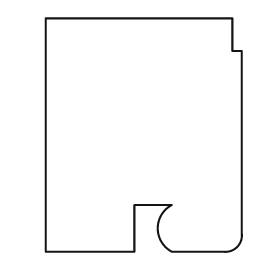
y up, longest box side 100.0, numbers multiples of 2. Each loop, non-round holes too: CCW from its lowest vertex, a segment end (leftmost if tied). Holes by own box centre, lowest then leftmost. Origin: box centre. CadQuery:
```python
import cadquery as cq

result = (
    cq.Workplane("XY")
    .moveTo(-42.0, -50.0)
    .lineTo(-4.0, -50.0)
    .lineTo(-4.0, -30.0)
    .lineTo(12.0, -30.0)
    .threePointArc((6.0, -40.0), (12.0, -50.0))
    .lineTo(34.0, -50.0)
    .threePointArc((40.0, -48.0), (42.0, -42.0))
    .lineTo(42.0, 36.0)
    .lineTo(38.0, 36.0)
    .lineTo(38.0, 50.0)
    .lineTo(-42.0, 50.0)
    .close()
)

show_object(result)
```